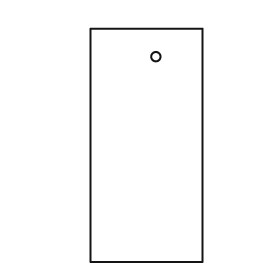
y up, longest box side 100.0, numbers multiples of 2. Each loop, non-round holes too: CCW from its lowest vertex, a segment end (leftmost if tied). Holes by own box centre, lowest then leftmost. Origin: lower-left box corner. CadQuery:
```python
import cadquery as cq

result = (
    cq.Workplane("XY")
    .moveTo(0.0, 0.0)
    .lineTo(48.0, 0.0)
    .lineTo(48.0, 100.0)
    .lineTo(0.0, 100.0)
    .close()
    .moveTo(28.0, 88.0)
    .circle(2.0)
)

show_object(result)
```